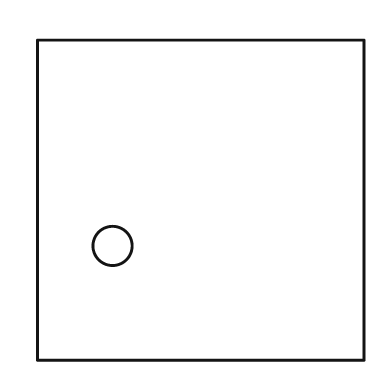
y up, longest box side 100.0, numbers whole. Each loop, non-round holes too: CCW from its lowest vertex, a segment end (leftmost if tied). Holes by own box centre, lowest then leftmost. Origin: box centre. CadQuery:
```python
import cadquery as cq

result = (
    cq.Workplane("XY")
    .moveTo(-50.0, -49.0)
    .lineTo(50.0, -49.0)
    .lineTo(50.0, 49.0)
    .lineTo(-50.0, 49.0)
    .close()
    .moveTo(-27.0, -14.0)
    .circle(6.0)
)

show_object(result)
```